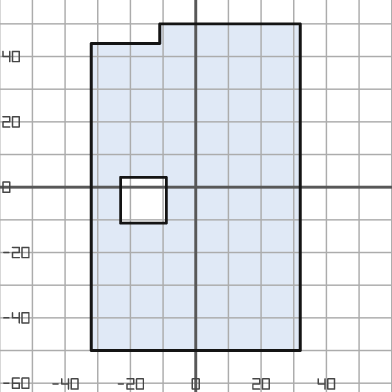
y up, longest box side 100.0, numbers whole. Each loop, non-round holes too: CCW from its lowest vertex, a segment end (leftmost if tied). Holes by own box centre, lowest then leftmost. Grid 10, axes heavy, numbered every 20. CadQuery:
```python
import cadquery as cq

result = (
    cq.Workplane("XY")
    .moveTo(-32.0, -50.0)
    .lineTo(32.0, -50.0)
    .lineTo(32.0, 50.0)
    .lineTo(-11.0, 50.0)
    .lineTo(-11.0, 44.0)
    .lineTo(-32.0, 44.0)
    .close()
    .moveTo(-23.0, -11.0)
    .lineTo(-9.0, -11.0)
    .lineTo(-9.0, 3.0)
    .lineTo(-23.0, 3.0)
    .close()
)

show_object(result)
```